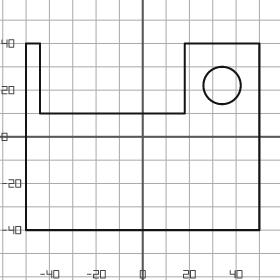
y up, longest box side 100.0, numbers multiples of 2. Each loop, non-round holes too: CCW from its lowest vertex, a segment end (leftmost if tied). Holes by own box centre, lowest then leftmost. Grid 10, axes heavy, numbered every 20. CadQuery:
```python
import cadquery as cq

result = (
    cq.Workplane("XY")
    .moveTo(-50.0, -40.0)
    .lineTo(50.0, -40.0)
    .lineTo(50.0, 40.0)
    .lineTo(18.0, 40.0)
    .lineTo(18.0, 10.0)
    .lineTo(-44.0, 10.0)
    .lineTo(-44.0, 40.0)
    .lineTo(-50.0, 40.0)
    .close()
    .moveTo(34.0, 22.0)
    .circle(8.0)
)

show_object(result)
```